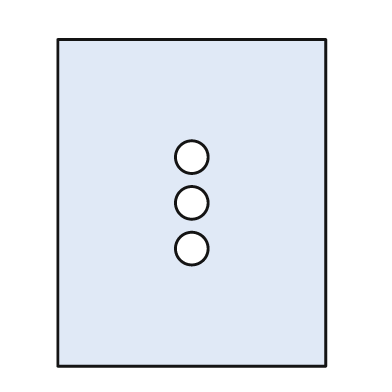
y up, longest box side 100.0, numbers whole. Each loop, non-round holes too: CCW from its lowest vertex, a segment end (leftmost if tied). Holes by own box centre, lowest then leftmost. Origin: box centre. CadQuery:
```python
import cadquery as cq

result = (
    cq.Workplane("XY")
    .moveTo(-41.0, -50.0)
    .lineTo(41.0, -50.0)
    .lineTo(41.0, 50.0)
    .lineTo(-41.0, 50.0)
    .close()
    .moveTo(0.0, -14.0)
    .circle(5.0)
    .moveTo(0.0, 0.0)
    .circle(5.0)
    .moveTo(0.0, 14.0)
    .circle(5.0)
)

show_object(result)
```